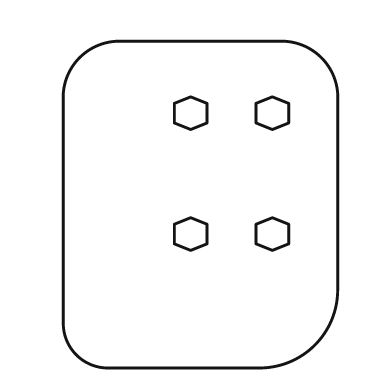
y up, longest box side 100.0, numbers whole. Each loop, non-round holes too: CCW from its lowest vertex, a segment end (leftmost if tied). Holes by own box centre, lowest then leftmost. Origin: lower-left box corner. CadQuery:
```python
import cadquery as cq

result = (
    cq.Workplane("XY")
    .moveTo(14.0, 0.0)
    .lineTo(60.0, 0.0)
    .threePointArc((77.0, 7.0), (84.0, 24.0))
    .lineTo(84.0, 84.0)
    .threePointArc((79.0, 95.0), (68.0, 100.0))
    .lineTo(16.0, 100.0)
    .threePointArc((5.0, 95.0), (0.0, 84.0))
    .lineTo(0.0, 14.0)
    .threePointArc((4.0, 4.0), (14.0, 0.0))
    .close()
    .moveTo(39.0, 36.0)
    .lineTo(44.0, 38.0)
    .lineTo(44.0, 44.0)
    .lineTo(39.0, 46.0)
    .lineTo(34.0, 44.0)
    .lineTo(34.0, 38.0)
    .close()
    .moveTo(64.0, 36.0)
    .lineTo(69.0, 38.0)
    .lineTo(69.0, 44.0)
    .lineTo(64.0, 46.0)
    .lineTo(59.0, 44.0)
    .lineTo(59.0, 38.0)
    .close()
    .moveTo(39.0, 73.0)
    .lineTo(44.0, 75.0)
    .lineTo(44.0, 81.0)
    .lineTo(39.0, 83.0)
    .lineTo(34.0, 81.0)
    .lineTo(34.0, 75.0)
    .close()
    .moveTo(64.0, 73.0)
    .lineTo(69.0, 75.0)
    .lineTo(69.0, 81.0)
    .lineTo(64.0, 83.0)
    .lineTo(59.0, 81.0)
    .lineTo(59.0, 75.0)
    .close()
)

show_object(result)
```